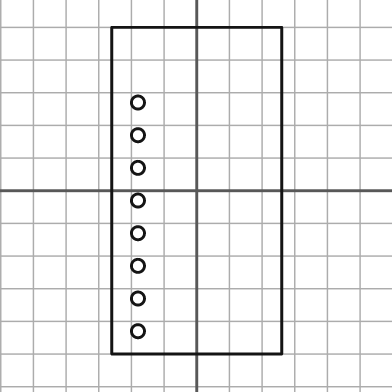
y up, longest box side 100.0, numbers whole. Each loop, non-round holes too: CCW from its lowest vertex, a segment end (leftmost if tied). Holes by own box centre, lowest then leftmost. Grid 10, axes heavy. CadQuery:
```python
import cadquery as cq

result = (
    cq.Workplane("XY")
    .moveTo(-26.0, -50.0)
    .lineTo(26.0, -50.0)
    .lineTo(26.0, 50.0)
    .lineTo(-26.0, 50.0)
    .close()
    .moveTo(-18.0, -43.0)
    .circle(2.0)
    .moveTo(-18.0, -33.0)
    .circle(2.0)
    .moveTo(-18.0, -23.0)
    .circle(2.0)
    .moveTo(-18.0, -13.0)
    .circle(2.0)
    .moveTo(-18.0, -3.0)
    .circle(2.0)
    .moveTo(-18.0, 7.0)
    .circle(2.0)
    .moveTo(-18.0, 17.0)
    .circle(2.0)
    .moveTo(-18.0, 27.0)
    .circle(2.0)
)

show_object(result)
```